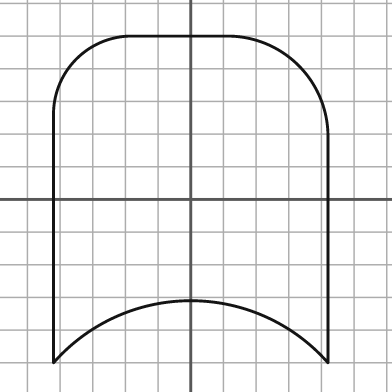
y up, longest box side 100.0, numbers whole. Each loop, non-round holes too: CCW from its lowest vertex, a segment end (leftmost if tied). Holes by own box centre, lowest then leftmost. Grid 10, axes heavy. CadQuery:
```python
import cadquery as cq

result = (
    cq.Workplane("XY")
    .moveTo(-42.0, -50.0)
    .threePointArc((0.0, -31.0), (42.0, -50.0))
    .lineTo(42.0, 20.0)
    .threePointArc((33.0, 41.0), (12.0, 50.0))
    .lineTo(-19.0, 50.0)
    .threePointArc((-35.0, 43.0), (-42.0, 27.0))
    .close()
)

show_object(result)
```